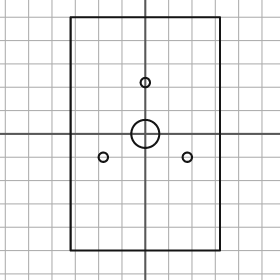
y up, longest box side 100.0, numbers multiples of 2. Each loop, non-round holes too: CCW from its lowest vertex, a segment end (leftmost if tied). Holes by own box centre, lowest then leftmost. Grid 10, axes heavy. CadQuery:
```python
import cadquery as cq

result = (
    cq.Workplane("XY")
    .moveTo(-32.0, -50.0)
    .lineTo(32.0, -50.0)
    .lineTo(32.0, 50.0)
    .lineTo(-32.0, 50.0)
    .close()
    .moveTo(-18.0, -10.0)
    .circle(2.0)
    .moveTo(18.0, -10.0)
    .circle(2.0)
    .moveTo(0.0, 0.0)
    .circle(6.0)
    .moveTo(0.0, 22.0)
    .circle(2.0)
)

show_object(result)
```